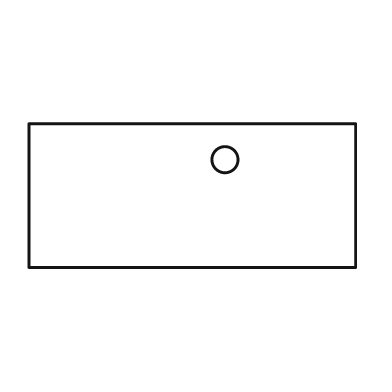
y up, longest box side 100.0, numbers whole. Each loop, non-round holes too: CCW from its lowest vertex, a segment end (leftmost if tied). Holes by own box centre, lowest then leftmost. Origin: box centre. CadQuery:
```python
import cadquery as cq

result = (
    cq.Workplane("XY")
    .moveTo(-50.0, -22.0)
    .lineTo(50.0, -22.0)
    .lineTo(50.0, 22.0)
    .lineTo(-50.0, 22.0)
    .close()
    .moveTo(10.0, 11.0)
    .circle(4.0)
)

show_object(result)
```